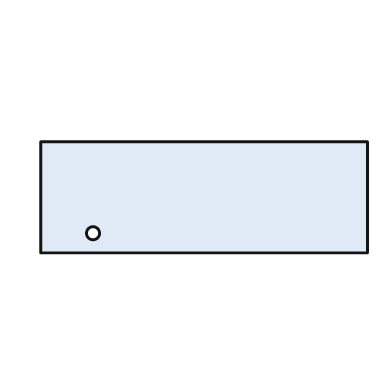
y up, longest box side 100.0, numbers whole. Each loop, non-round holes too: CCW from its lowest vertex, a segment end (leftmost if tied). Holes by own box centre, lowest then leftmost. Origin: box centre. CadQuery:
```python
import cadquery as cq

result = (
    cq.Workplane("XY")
    .moveTo(-50.0, -17.0)
    .lineTo(50.0, -17.0)
    .lineTo(50.0, 17.0)
    .lineTo(-50.0, 17.0)
    .close()
    .moveTo(-34.0, -11.0)
    .circle(2.0)
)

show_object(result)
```